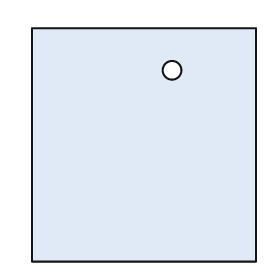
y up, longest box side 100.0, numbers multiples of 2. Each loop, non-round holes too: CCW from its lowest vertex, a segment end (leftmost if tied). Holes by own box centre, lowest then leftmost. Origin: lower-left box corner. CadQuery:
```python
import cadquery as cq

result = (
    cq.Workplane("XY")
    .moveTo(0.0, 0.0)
    .lineTo(96.0, 0.0)
    .lineTo(96.0, 100.0)
    .lineTo(0.0, 100.0)
    .close()
    .moveTo(60.0, 82.0)
    .circle(4.0)
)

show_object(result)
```